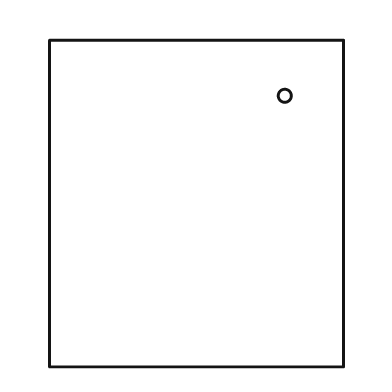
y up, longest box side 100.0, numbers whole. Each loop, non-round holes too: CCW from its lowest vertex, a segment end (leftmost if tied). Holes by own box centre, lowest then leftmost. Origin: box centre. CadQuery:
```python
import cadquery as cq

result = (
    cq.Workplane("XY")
    .moveTo(-45.0, -50.0)
    .lineTo(45.0, -50.0)
    .lineTo(45.0, 50.0)
    .lineTo(-45.0, 50.0)
    .close()
    .moveTo(27.0, 33.0)
    .circle(2.0)
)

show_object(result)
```